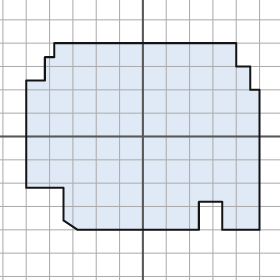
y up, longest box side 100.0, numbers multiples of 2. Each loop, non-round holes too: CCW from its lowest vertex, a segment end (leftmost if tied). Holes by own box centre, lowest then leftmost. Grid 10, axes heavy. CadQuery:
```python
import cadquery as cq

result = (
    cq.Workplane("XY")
    .moveTo(-28.0, -40.0)
    .lineTo(24.0, -40.0)
    .lineTo(24.0, -28.0)
    .lineTo(34.0, -28.0)
    .lineTo(34.0, -40.0)
    .lineTo(50.0, -40.0)
    .lineTo(50.0, 20.0)
    .lineTo(46.0, 20.0)
    .lineTo(46.0, 30.0)
    .lineTo(40.0, 30.0)
    .lineTo(40.0, 40.0)
    .lineTo(-38.0, 40.0)
    .lineTo(-38.0, 34.0)
    .lineTo(-42.0, 34.0)
    .lineTo(-42.0, 24.0)
    .lineTo(-50.0, 24.0)
    .lineTo(-50.0, -22.0)
    .lineTo(-34.0, -22.0)
    .lineTo(-34.0, -36.0)
    .close()
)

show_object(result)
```